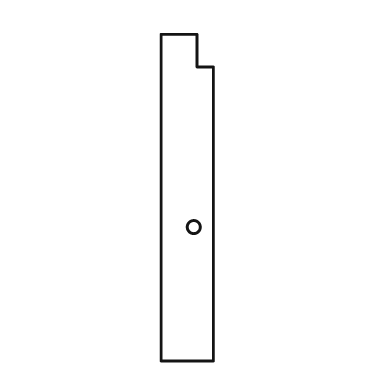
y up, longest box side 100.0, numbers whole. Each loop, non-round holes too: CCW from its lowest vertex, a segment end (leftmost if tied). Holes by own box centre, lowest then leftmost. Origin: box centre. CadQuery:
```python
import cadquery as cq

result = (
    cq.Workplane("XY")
    .moveTo(-8.0, -50.0)
    .lineTo(8.0, -50.0)
    .lineTo(8.0, 40.0)
    .lineTo(3.0, 40.0)
    .lineTo(3.0, 50.0)
    .lineTo(-8.0, 50.0)
    .close()
    .moveTo(2.0, -9.0)
    .circle(2.0)
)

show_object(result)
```